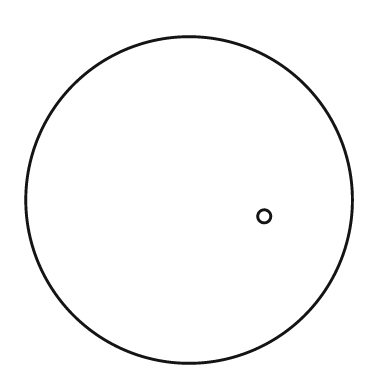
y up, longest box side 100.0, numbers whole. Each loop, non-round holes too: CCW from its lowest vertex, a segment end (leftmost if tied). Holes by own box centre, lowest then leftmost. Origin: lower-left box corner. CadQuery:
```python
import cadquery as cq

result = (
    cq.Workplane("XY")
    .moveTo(50.0, 50.0)
    .circle(50.0)
    .moveTo(73.0, 45.0)
    .circle(2.0)
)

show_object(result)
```